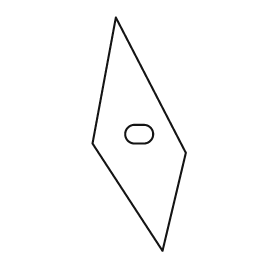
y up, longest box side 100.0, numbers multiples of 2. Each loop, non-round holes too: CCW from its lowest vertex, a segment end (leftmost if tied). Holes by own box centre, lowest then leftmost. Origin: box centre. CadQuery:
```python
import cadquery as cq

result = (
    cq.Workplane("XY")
    .moveTo(10.0, -50.0)
    .lineTo(20.0, -8.0)
    .lineTo(-10.0, 50.0)
    .lineTo(-20.0, -4.0)
    .close()
    .moveTo(-2.0, -4.0)
    .lineTo(2.0, -4.0)
    .threePointArc((6.0, 0.0), (2.0, 4.0))
    .lineTo(-2.0, 4.0)
    .threePointArc((-6.0, 0.0), (-2.0, -4.0))
    .close()
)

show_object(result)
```